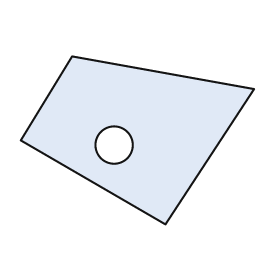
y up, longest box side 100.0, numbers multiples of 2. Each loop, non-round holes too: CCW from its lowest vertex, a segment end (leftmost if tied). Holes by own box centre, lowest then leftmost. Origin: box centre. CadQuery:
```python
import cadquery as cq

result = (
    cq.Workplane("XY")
    .moveTo(12.0, -36.0)
    .lineTo(50.0, 22.0)
    .lineTo(-28.0, 36.0)
    .lineTo(-50.0, 0.0)
    .close()
    .moveTo(-10.0, -2.0)
    .circle(8.0)
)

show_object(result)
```